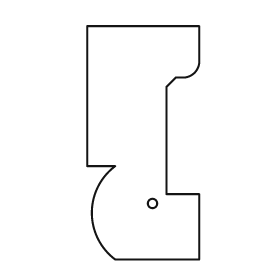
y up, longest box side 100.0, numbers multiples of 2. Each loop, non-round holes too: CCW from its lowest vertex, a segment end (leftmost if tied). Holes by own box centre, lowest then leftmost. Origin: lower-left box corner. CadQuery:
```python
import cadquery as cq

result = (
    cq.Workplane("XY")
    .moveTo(12.0, 0.0)
    .lineTo(48.0, 0.0)
    .lineTo(48.0, 28.0)
    .lineTo(34.0, 28.0)
    .lineTo(34.0, 74.0)
    .lineTo(38.0, 78.0)
    .lineTo(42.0, 78.0)
    .threePointArc((46.0, 80.0), (48.0, 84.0))
    .lineTo(48.0, 100.0)
    .lineTo(0.0, 100.0)
    .lineTo(0.0, 40.0)
    .lineTo(12.0, 40.0)
    .threePointArc((2.0, 20.0), (12.0, 0.0))
    .close()
    .moveTo(28.0, 24.0)
    .circle(2.0)
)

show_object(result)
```